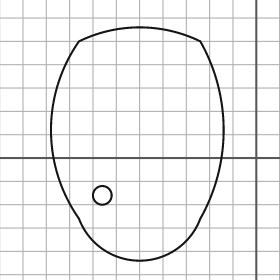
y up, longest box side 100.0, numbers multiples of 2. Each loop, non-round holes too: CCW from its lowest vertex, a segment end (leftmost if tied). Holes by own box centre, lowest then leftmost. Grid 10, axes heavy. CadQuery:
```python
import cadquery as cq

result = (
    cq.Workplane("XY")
    .moveTo(-76.0, -26.0)
    .threePointArc((-50.0, -44.0), (-24.0, -26.0))
    .threePointArc((-14.0, 12.0), (-24.0, 50.0))
    .threePointArc((-50.0, 56.0), (-76.0, 50.0))
    .threePointArc((-88.0, 12.0), (-76.0, -26.0))
    .close()
    .moveTo(-66.0, -16.0)
    .circle(4.0)
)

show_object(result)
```